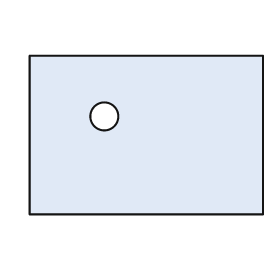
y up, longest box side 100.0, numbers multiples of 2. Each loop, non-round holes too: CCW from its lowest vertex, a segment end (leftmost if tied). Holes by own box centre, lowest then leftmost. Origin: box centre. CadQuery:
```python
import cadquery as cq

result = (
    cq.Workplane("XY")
    .moveTo(-50.0, -34.0)
    .lineTo(50.0, -34.0)
    .lineTo(50.0, 34.0)
    .lineTo(-50.0, 34.0)
    .close()
    .moveTo(-18.0, 8.0)
    .circle(6.0)
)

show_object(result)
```